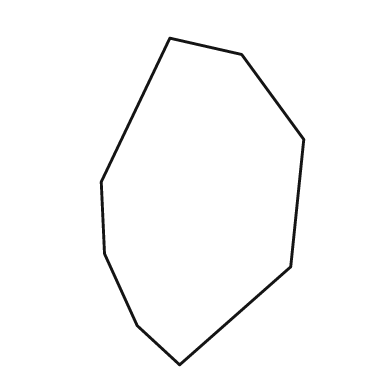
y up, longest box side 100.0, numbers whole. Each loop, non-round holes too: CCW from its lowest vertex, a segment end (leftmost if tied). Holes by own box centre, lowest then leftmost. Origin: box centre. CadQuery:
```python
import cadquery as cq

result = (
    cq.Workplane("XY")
    .moveTo(-7.0, -50.0)
    .lineTo(27.0, -20.0)
    .lineTo(31.0, 19.0)
    .lineTo(12.0, 45.0)
    .lineTo(-10.0, 50.0)
    .lineTo(-31.0, 6.0)
    .lineTo(-30.0, -16.0)
    .lineTo(-20.0, -38.0)
    .close()
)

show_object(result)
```